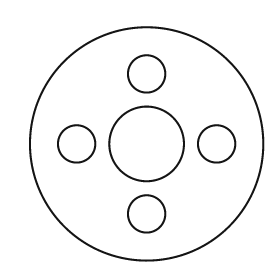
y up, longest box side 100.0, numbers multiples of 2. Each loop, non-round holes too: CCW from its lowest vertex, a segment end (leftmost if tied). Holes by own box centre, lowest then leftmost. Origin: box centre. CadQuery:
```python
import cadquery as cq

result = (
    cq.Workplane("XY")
    .moveTo(0.0, 0.0)
    .circle(50.0)
    .moveTo(0.0, -30.0)
    .circle(8.0)
    .moveTo(-30.0, 0.0)
    .circle(8.0)
    .moveTo(0.0, 0.0)
    .circle(16.0)
    .moveTo(30.0, 0.0)
    .circle(8.0)
    .moveTo(0.0, 30.0)
    .circle(8.0)
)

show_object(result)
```